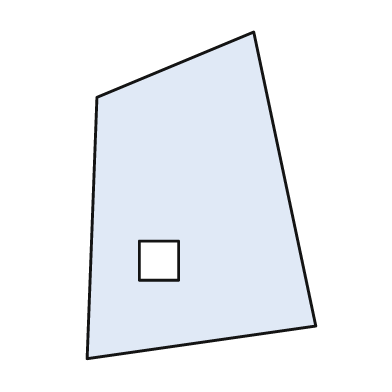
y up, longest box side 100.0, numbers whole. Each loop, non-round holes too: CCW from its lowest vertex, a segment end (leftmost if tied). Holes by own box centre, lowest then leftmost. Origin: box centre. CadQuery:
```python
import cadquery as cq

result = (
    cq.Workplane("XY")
    .moveTo(-35.0, -50.0)
    .lineTo(35.0, -40.0)
    .lineTo(16.0, 50.0)
    .lineTo(-32.0, 30.0)
    .close()
    .moveTo(-19.0, -26.0)
    .lineTo(-7.0, -26.0)
    .lineTo(-7.0, -14.0)
    .lineTo(-19.0, -14.0)
    .close()
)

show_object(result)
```